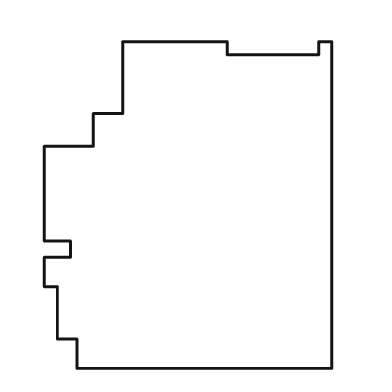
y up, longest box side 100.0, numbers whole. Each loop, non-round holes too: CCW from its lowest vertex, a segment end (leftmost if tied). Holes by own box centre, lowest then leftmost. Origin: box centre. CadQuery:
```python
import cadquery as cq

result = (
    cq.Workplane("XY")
    .moveTo(-34.0, -50.0)
    .lineTo(44.0, -50.0)
    .lineTo(44.0, 50.0)
    .lineTo(40.0, 50.0)
    .lineTo(40.0, 46.0)
    .lineTo(12.0, 46.0)
    .lineTo(12.0, 50.0)
    .lineTo(-20.0, 50.0)
    .lineTo(-20.0, 28.0)
    .lineTo(-29.0, 28.0)
    .lineTo(-29.0, 18.0)
    .lineTo(-44.0, 18.0)
    .lineTo(-44.0, -11.0)
    .lineTo(-36.0, -11.0)
    .lineTo(-36.0, -16.0)
    .lineTo(-44.0, -16.0)
    .lineTo(-44.0, -25.0)
    .lineTo(-40.0, -25.0)
    .lineTo(-40.0, -41.0)
    .lineTo(-34.0, -41.0)
    .close()
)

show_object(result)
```